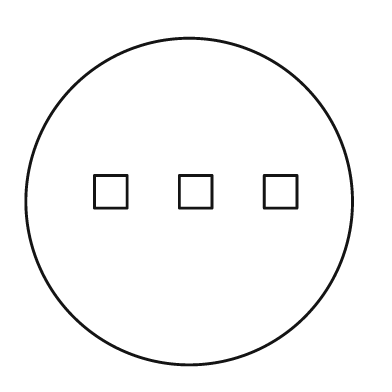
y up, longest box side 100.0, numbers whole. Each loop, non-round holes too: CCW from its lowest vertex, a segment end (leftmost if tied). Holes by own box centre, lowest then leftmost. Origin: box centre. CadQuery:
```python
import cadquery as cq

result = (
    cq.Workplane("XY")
    .moveTo(0.0, 0.0)
    .circle(50.0)
    .moveTo(-29.0, -2.0)
    .lineTo(-19.0, -2.0)
    .lineTo(-19.0, 8.0)
    .lineTo(-29.0, 8.0)
    .close()
    .moveTo(-3.0, -2.0)
    .lineTo(7.0, -2.0)
    .lineTo(7.0, 8.0)
    .lineTo(-3.0, 8.0)
    .close()
    .moveTo(23.0, -2.0)
    .lineTo(33.0, -2.0)
    .lineTo(33.0, 8.0)
    .lineTo(23.0, 8.0)
    .close()
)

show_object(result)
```